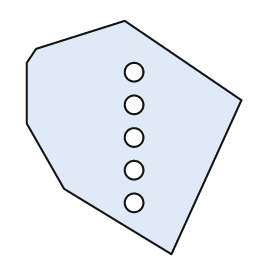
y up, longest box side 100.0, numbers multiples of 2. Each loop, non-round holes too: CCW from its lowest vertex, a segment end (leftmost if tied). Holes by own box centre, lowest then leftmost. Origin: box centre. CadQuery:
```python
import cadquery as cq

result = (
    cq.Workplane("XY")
    .moveTo(16.0, -50.0)
    .lineTo(46.0, 16.0)
    .lineTo(-4.0, 50.0)
    .lineTo(-42.0, 38.0)
    .lineTo(-46.0, 32.0)
    .lineTo(-46.0, 6.0)
    .lineTo(-30.0, -22.0)
    .close()
    .moveTo(0.0, -28.0)
    .circle(4.0)
    .moveTo(0.0, -14.0)
    .circle(4.0)
    .moveTo(0.0, 0.0)
    .circle(4.0)
    .moveTo(0.0, 14.0)
    .circle(4.0)
    .moveTo(0.0, 28.0)
    .circle(4.0)
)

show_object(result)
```